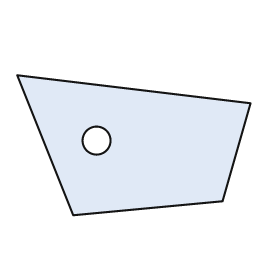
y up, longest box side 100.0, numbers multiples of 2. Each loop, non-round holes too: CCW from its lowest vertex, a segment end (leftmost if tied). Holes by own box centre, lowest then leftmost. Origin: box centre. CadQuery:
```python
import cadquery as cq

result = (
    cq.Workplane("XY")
    .moveTo(-26.0, -30.0)
    .lineTo(38.0, -24.0)
    .lineTo(50.0, 18.0)
    .lineTo(-50.0, 30.0)
    .close()
    .moveTo(-16.0, 2.0)
    .circle(6.0)
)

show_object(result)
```